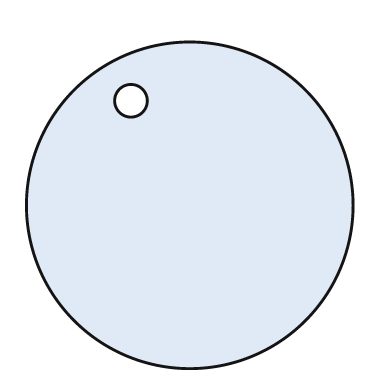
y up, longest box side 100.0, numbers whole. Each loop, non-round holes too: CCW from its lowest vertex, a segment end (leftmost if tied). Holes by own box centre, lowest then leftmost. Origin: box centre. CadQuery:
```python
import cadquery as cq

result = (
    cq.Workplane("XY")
    .moveTo(0.0, 0.0)
    .circle(50.0)
    .moveTo(-18.0, 32.0)
    .circle(5.0)
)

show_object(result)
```